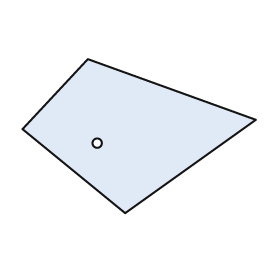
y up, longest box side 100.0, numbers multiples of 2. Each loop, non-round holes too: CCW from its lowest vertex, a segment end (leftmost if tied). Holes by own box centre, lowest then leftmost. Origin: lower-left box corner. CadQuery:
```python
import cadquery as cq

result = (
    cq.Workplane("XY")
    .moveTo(44.0, 0.0)
    .lineTo(100.0, 40.0)
    .lineTo(28.0, 66.0)
    .lineTo(0.0, 36.0)
    .close()
    .moveTo(32.0, 30.0)
    .circle(2.0)
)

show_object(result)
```